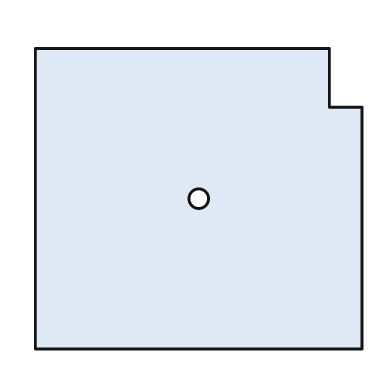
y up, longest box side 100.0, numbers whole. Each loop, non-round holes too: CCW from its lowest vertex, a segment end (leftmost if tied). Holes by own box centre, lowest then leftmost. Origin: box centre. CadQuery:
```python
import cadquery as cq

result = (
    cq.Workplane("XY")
    .moveTo(-50.0, -46.0)
    .lineTo(50.0, -46.0)
    .lineTo(50.0, 28.0)
    .lineTo(40.0, 28.0)
    .lineTo(40.0, 46.0)
    .lineTo(-50.0, 46.0)
    .close()
    .moveTo(0.0, 0.0)
    .circle(3.0)
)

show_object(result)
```